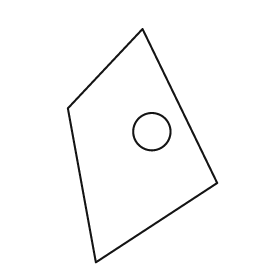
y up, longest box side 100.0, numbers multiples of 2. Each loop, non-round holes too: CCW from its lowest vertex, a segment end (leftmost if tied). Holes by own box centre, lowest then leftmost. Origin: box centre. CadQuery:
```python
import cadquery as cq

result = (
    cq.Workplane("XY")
    .moveTo(-20.0, -50.0)
    .lineTo(32.0, -16.0)
    .lineTo(0.0, 50.0)
    .lineTo(-32.0, 16.0)
    .close()
    .moveTo(4.0, 6.0)
    .circle(8.0)
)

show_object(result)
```